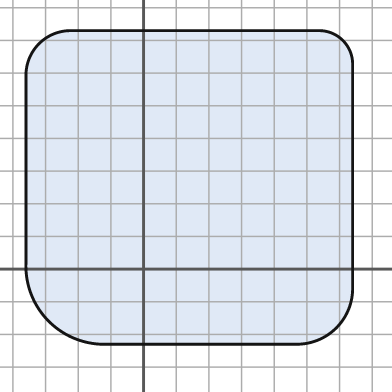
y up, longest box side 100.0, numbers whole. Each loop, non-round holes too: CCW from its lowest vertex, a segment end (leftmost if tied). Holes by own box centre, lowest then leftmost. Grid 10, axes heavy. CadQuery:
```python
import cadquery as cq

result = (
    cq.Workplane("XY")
    .moveTo(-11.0, -23.0)
    .lineTo(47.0, -23.0)
    .threePointArc((59.0, -18.0), (64.0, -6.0))
    .lineTo(64.0, 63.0)
    .threePointArc((61.0, 70.0), (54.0, 73.0))
    .lineTo(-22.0, 73.0)
    .threePointArc((-32.0, 69.0), (-36.0, 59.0))
    .lineTo(-36.0, 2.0)
    .threePointArc((-29.0, -16.0), (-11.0, -23.0))
    .close()
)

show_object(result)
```